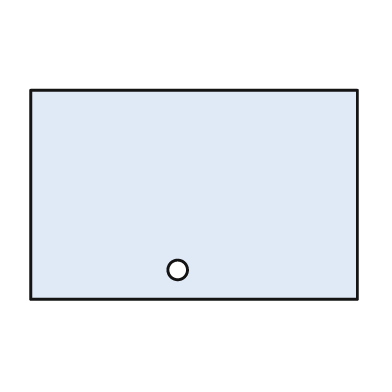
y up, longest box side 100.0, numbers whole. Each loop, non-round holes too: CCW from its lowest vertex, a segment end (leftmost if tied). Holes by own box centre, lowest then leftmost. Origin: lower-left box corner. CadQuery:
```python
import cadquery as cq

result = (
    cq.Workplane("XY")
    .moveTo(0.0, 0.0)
    .lineTo(100.0, 0.0)
    .lineTo(100.0, 64.0)
    .lineTo(0.0, 64.0)
    .close()
    .moveTo(45.0, 9.0)
    .circle(3.0)
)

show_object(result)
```